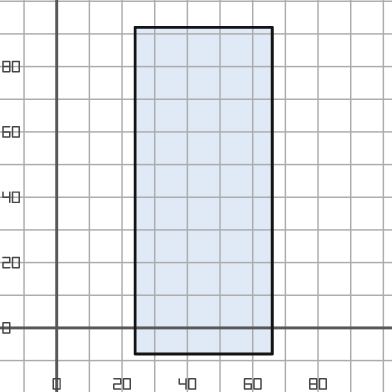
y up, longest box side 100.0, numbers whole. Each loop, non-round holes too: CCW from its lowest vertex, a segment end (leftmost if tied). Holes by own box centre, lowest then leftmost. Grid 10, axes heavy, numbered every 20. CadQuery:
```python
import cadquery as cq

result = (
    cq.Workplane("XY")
    .moveTo(24.0, -8.0)
    .lineTo(66.0, -8.0)
    .lineTo(66.0, 92.0)
    .lineTo(24.0, 92.0)
    .close()
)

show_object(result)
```